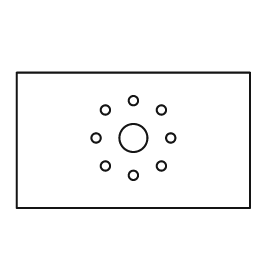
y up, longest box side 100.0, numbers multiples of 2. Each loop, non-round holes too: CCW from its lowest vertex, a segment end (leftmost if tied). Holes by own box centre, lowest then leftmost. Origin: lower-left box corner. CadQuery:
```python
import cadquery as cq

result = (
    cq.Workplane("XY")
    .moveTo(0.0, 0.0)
    .lineTo(100.0, 0.0)
    .lineTo(100.0, 58.0)
    .lineTo(0.0, 58.0)
    .close()
    .moveTo(50.0, 14.0)
    .circle(2.0)
    .moveTo(38.0, 18.0)
    .circle(2.0)
    .moveTo(62.0, 18.0)
    .circle(2.0)
    .moveTo(34.0, 30.0)
    .circle(2.0)
    .moveTo(50.0, 30.0)
    .circle(6.0)
    .moveTo(66.0, 30.0)
    .circle(2.0)
    .moveTo(38.0, 42.0)
    .circle(2.0)
    .moveTo(62.0, 42.0)
    .circle(2.0)
    .moveTo(50.0, 46.0)
    .circle(2.0)
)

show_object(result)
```